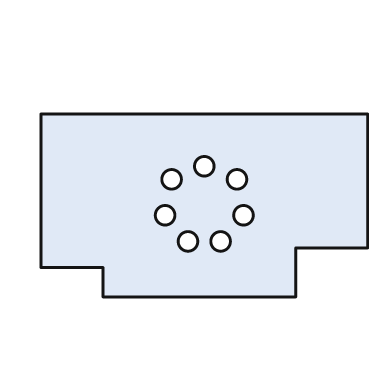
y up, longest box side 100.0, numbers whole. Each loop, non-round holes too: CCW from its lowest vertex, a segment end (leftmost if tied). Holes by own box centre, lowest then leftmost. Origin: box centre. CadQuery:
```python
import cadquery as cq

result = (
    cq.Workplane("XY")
    .moveTo(-31.0, -28.0)
    .lineTo(28.0, -28.0)
    .lineTo(28.0, -13.0)
    .lineTo(50.0, -13.0)
    .lineTo(50.0, 28.0)
    .lineTo(-50.0, 28.0)
    .lineTo(-50.0, -19.0)
    .lineTo(-31.0, -19.0)
    .close()
    .moveTo(-5.0, -11.0)
    .circle(3.0)
    .moveTo(5.0, -11.0)
    .circle(3.0)
    .moveTo(-12.0, -3.0)
    .circle(3.0)
    .moveTo(12.0, -3.0)
    .circle(3.0)
    .moveTo(-10.0, 8.0)
    .circle(3.0)
    .moveTo(10.0, 8.0)
    .circle(3.0)
    .moveTo(0.0, 12.0)
    .circle(3.0)
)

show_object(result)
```